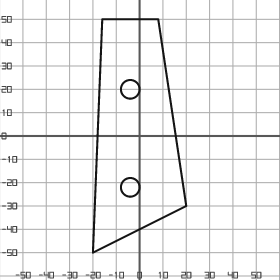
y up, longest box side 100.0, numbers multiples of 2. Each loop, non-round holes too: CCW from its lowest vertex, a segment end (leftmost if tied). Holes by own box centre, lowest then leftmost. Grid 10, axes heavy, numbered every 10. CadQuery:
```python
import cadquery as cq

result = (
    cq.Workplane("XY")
    .moveTo(-20.0, -50.0)
    .lineTo(20.0, -30.0)
    .lineTo(8.0, 50.0)
    .lineTo(-16.0, 50.0)
    .close()
    .moveTo(-4.0, -22.0)
    .circle(4.0)
    .moveTo(-4.0, 20.0)
    .circle(4.0)
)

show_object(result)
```